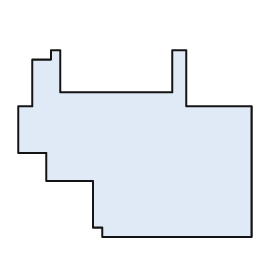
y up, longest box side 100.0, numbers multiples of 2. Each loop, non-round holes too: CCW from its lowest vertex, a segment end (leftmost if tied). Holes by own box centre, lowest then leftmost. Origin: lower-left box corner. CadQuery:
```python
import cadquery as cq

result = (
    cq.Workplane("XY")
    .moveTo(36.0, 0.0)
    .lineTo(100.0, 0.0)
    .lineTo(100.0, 56.0)
    .lineTo(72.0, 56.0)
    .lineTo(72.0, 80.0)
    .lineTo(66.0, 80.0)
    .lineTo(66.0, 62.0)
    .lineTo(18.0, 62.0)
    .lineTo(18.0, 80.0)
    .lineTo(14.0, 80.0)
    .lineTo(14.0, 76.0)
    .lineTo(6.0, 76.0)
    .lineTo(6.0, 56.0)
    .lineTo(0.0, 56.0)
    .lineTo(0.0, 36.0)
    .lineTo(12.0, 36.0)
    .lineTo(12.0, 24.0)
    .lineTo(32.0, 24.0)
    .lineTo(32.0, 4.0)
    .lineTo(36.0, 4.0)
    .close()
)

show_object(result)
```